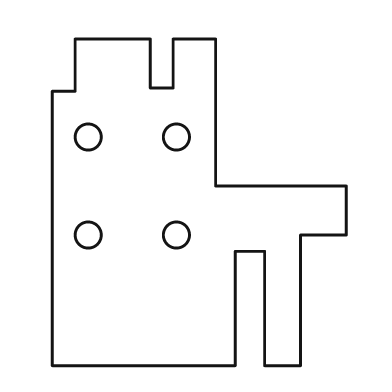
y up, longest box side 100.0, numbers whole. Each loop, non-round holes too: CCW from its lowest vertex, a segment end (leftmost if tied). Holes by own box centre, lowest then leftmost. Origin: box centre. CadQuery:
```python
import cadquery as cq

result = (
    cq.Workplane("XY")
    .moveTo(-45.0, -50.0)
    .lineTo(11.0, -50.0)
    .lineTo(11.0, -15.0)
    .lineTo(20.0, -15.0)
    .lineTo(20.0, -50.0)
    .lineTo(31.0, -50.0)
    .lineTo(31.0, -10.0)
    .lineTo(45.0, -10.0)
    .lineTo(45.0, 5.0)
    .lineTo(5.0, 5.0)
    .lineTo(5.0, 50.0)
    .lineTo(-8.0, 50.0)
    .lineTo(-8.0, 35.0)
    .lineTo(-15.0, 35.0)
    .lineTo(-15.0, 50.0)
    .lineTo(-38.0, 50.0)
    .lineTo(-38.0, 34.0)
    .lineTo(-45.0, 34.0)
    .close()
    .moveTo(-34.0, -10.0)
    .circle(4.0)
    .moveTo(-7.0, -10.0)
    .circle(4.0)
    .moveTo(-34.0, 20.0)
    .circle(4.0)
    .moveTo(-7.0, 20.0)
    .circle(4.0)
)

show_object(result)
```